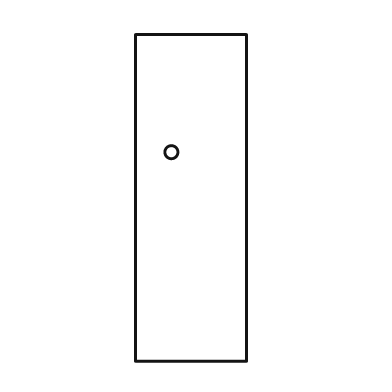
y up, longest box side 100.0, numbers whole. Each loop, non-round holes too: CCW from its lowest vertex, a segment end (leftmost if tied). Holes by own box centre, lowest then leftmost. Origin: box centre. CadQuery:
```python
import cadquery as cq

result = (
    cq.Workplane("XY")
    .moveTo(-17.0, -50.0)
    .lineTo(17.0, -50.0)
    .lineTo(17.0, 50.0)
    .lineTo(-17.0, 50.0)
    .close()
    .moveTo(-6.0, 14.0)
    .circle(2.0)
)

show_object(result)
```